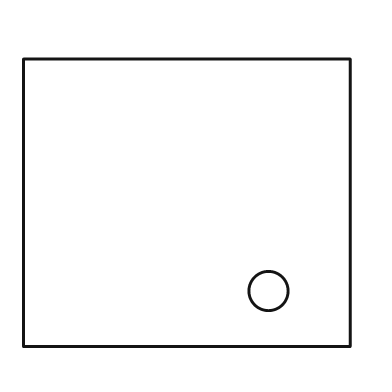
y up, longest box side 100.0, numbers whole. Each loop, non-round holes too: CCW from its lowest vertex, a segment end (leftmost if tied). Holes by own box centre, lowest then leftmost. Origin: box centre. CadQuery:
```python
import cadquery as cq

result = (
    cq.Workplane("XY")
    .moveTo(-50.0, -44.0)
    .lineTo(50.0, -44.0)
    .lineTo(50.0, 44.0)
    .lineTo(-50.0, 44.0)
    .close()
    .moveTo(25.0, -27.0)
    .circle(6.0)
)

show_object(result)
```